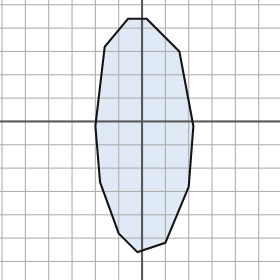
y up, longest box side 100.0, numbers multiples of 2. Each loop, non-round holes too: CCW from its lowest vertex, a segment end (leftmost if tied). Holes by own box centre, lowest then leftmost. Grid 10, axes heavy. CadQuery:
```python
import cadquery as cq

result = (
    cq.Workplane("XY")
    .moveTo(-2.0, -56.0)
    .lineTo(10.0, -52.0)
    .lineTo(20.0, -28.0)
    .lineTo(22.0, -2.0)
    .lineTo(16.0, 30.0)
    .lineTo(2.0, 44.0)
    .lineTo(-6.0, 44.0)
    .lineTo(-16.0, 32.0)
    .lineTo(-20.0, -2.0)
    .lineTo(-18.0, -26.0)
    .lineTo(-10.0, -48.0)
    .close()
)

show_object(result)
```